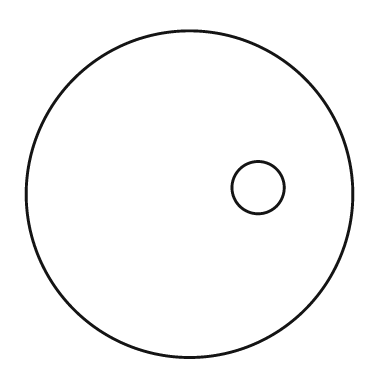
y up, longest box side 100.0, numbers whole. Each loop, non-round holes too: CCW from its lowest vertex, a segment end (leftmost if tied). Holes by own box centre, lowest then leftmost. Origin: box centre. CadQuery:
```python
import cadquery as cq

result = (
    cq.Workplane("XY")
    .moveTo(0.0, 0.0)
    .circle(50.0)
    .moveTo(21.0, 2.0)
    .circle(8.0)
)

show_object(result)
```